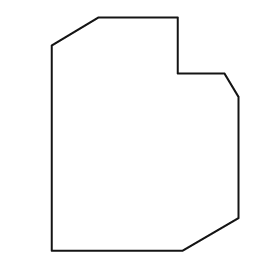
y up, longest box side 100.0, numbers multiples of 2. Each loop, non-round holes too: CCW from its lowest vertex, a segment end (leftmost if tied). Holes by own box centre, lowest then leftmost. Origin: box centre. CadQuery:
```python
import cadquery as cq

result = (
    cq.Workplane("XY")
    .moveTo(-40.0, -50.0)
    .lineTo(16.0, -50.0)
    .lineTo(40.0, -36.0)
    .lineTo(40.0, 16.0)
    .lineTo(34.0, 26.0)
    .lineTo(14.0, 26.0)
    .lineTo(14.0, 50.0)
    .lineTo(-20.0, 50.0)
    .lineTo(-40.0, 38.0)
    .close()
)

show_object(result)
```